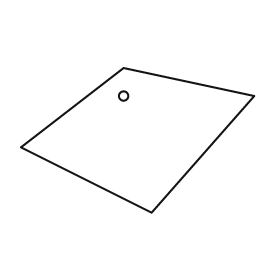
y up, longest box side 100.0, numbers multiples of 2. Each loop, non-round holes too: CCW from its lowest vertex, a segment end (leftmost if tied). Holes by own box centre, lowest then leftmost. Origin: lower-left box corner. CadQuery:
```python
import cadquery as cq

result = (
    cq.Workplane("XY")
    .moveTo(56.0, 0.0)
    .lineTo(100.0, 50.0)
    .lineTo(44.0, 62.0)
    .lineTo(0.0, 28.0)
    .close()
    .moveTo(44.0, 50.0)
    .circle(2.0)
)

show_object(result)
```